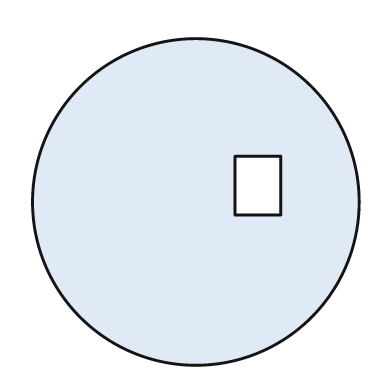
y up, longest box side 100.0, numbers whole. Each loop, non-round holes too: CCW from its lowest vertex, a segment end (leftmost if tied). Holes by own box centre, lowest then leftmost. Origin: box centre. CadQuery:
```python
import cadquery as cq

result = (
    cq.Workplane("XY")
    .moveTo(0.0, 0.0)
    .circle(50.0)
    .moveTo(12.0, -4.0)
    .lineTo(26.0, -4.0)
    .lineTo(26.0, 14.0)
    .lineTo(12.0, 14.0)
    .close()
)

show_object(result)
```